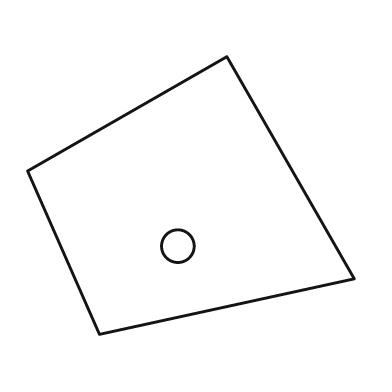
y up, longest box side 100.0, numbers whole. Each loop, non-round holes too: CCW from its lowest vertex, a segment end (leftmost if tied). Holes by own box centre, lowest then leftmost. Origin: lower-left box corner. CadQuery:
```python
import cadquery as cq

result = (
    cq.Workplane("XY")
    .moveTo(22.0, 0.0)
    .lineTo(100.0, 17.0)
    .lineTo(61.0, 85.0)
    .lineTo(0.0, 50.0)
    .close()
    .moveTo(46.0, 27.0)
    .circle(5.0)
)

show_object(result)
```